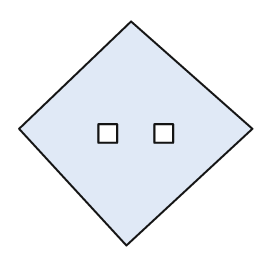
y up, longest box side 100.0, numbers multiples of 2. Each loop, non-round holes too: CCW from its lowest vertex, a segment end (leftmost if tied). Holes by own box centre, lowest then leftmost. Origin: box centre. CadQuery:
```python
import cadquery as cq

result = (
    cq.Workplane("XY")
    .moveTo(-4.0, -48.0)
    .lineTo(50.0, 2.0)
    .lineTo(-2.0, 48.0)
    .lineTo(-50.0, 2.0)
    .close()
    .moveTo(-16.0, -4.0)
    .lineTo(-8.0, -4.0)
    .lineTo(-8.0, 4.0)
    .lineTo(-16.0, 4.0)
    .close()
    .moveTo(8.0, -4.0)
    .lineTo(16.0, -4.0)
    .lineTo(16.0, 4.0)
    .lineTo(8.0, 4.0)
    .close()
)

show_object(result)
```